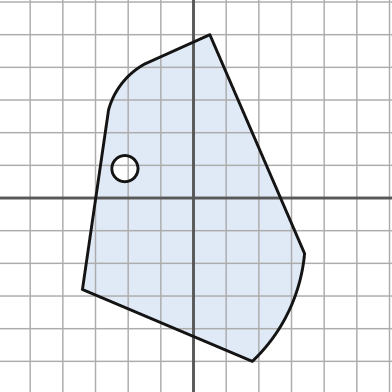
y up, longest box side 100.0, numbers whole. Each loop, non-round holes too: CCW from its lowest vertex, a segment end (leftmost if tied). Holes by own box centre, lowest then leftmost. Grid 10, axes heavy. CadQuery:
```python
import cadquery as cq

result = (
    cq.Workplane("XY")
    .moveTo(18.0, -50.0)
    .threePointArc((29.0, -35.0), (34.0, -17.0))
    .lineTo(5.0, 50.0)
    .lineTo(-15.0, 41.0)
    .threePointArc((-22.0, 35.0), (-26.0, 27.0))
    .lineTo(-34.0, -28.0)
    .close()
    .moveTo(-21.0, 9.0)
    .circle(4.0)
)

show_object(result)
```